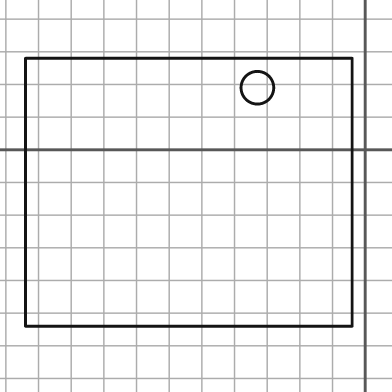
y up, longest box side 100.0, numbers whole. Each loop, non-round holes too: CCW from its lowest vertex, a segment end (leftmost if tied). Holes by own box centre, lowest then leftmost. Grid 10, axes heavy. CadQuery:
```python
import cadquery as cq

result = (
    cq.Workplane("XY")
    .moveTo(-104.0, -54.0)
    .lineTo(-4.0, -54.0)
    .lineTo(-4.0, 28.0)
    .lineTo(-104.0, 28.0)
    .close()
    .moveTo(-33.0, 19.0)
    .circle(5.0)
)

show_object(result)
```